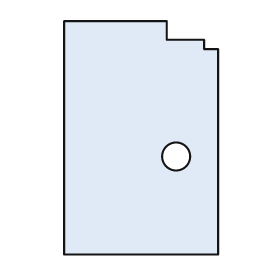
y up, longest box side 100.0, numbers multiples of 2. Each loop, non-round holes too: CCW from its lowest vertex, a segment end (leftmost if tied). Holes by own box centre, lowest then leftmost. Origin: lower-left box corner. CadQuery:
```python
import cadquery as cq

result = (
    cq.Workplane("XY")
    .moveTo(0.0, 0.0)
    .lineTo(66.0, 0.0)
    .lineTo(66.0, 88.0)
    .lineTo(60.0, 88.0)
    .lineTo(60.0, 92.0)
    .lineTo(44.0, 92.0)
    .lineTo(44.0, 100.0)
    .lineTo(0.0, 100.0)
    .close()
    .moveTo(48.0, 42.0)
    .circle(6.0)
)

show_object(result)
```